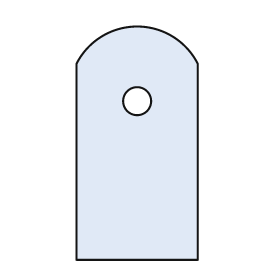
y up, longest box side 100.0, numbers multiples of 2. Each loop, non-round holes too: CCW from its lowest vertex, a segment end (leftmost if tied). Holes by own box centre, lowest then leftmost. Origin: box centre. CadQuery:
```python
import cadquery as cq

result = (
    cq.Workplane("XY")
    .moveTo(-26.0, -50.0)
    .lineTo(26.0, -50.0)
    .lineTo(26.0, 34.0)
    .threePointArc((0.0, 50.0), (-26.0, 34.0))
    .close()
    .moveTo(0.0, 18.0)
    .circle(6.0)
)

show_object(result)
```